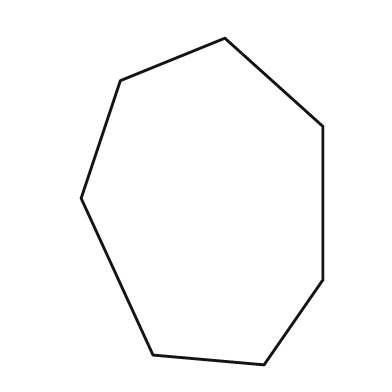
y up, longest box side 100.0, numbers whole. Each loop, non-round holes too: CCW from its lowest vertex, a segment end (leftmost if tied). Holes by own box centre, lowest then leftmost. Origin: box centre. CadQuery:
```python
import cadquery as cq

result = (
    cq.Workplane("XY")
    .moveTo(19.0, -50.0)
    .lineTo(37.0, -24.0)
    .lineTo(37.0, 23.0)
    .lineTo(7.0, 50.0)
    .lineTo(-25.0, 37.0)
    .lineTo(-37.0, 1.0)
    .lineTo(-15.0, -47.0)
    .close()
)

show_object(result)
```